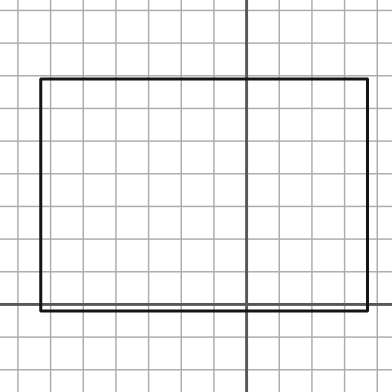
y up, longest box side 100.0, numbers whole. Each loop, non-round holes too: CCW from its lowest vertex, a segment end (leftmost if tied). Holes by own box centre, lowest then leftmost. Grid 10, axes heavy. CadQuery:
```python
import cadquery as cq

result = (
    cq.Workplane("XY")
    .moveTo(-63.0, -2.0)
    .lineTo(37.0, -2.0)
    .lineTo(37.0, 69.0)
    .lineTo(-63.0, 69.0)
    .close()
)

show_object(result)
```